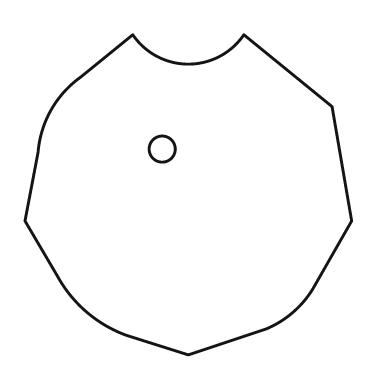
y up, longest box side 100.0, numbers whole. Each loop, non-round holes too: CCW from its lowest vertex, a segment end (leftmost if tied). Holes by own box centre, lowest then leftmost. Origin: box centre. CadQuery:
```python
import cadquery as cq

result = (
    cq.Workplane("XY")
    .moveTo(0.0, -49.0)
    .lineTo(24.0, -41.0)
    .threePointArc((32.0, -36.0), (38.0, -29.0))
    .lineTo(50.0, -8.0)
    .lineTo(44.0, 27.0)
    .lineTo(17.0, 49.0)
    .threePointArc((0.0, 40.0), (-17.0, 49.0))
    .lineTo(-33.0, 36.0)
    .threePointArc((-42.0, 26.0), (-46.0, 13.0))
    .lineTo(-50.0, -8.0)
    .lineTo(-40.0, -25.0)
    .threePointArc((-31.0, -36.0), (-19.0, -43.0))
    .close()
    .moveTo(-8.0, 14.0)
    .circle(4.0)
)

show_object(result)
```